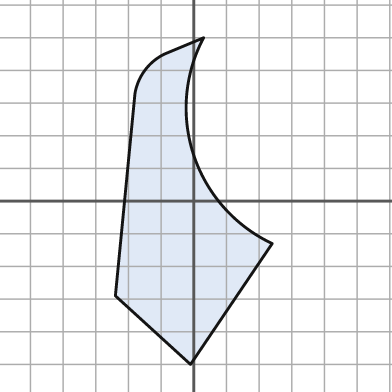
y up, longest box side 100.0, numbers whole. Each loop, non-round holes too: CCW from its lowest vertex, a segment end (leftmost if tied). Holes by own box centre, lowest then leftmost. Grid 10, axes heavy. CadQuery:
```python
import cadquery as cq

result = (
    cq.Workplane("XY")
    .moveTo(-1.0, -50.0)
    .lineTo(24.0, -13.0)
    .threePointArc((0.0, 14.0), (3.0, 50.0))
    .lineTo(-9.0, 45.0)
    .threePointArc((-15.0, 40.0), (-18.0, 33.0))
    .lineTo(-24.0, -29.0)
    .close()
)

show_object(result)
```